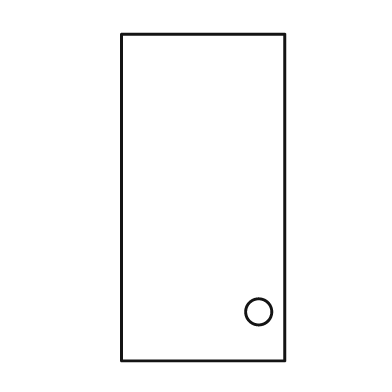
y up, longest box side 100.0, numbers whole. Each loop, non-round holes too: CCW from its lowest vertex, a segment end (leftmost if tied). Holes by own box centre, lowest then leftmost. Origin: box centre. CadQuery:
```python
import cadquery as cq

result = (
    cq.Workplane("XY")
    .moveTo(-25.0, -50.0)
    .lineTo(25.0, -50.0)
    .lineTo(25.0, 50.0)
    .lineTo(-25.0, 50.0)
    .close()
    .moveTo(17.0, -35.0)
    .circle(4.0)
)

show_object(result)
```